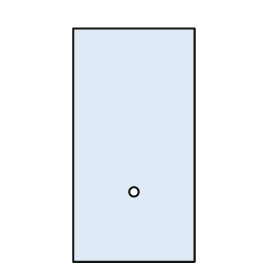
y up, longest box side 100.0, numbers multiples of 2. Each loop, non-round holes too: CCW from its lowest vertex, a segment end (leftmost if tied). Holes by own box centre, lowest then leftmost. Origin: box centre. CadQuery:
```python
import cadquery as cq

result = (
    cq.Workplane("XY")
    .moveTo(-26.0, -50.0)
    .lineTo(26.0, -50.0)
    .lineTo(26.0, 50.0)
    .lineTo(-26.0, 50.0)
    .close()
    .moveTo(0.0, -20.0)
    .circle(2.0)
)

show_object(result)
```